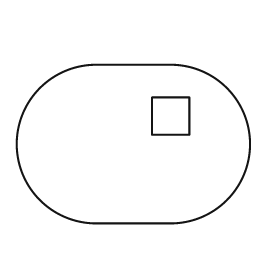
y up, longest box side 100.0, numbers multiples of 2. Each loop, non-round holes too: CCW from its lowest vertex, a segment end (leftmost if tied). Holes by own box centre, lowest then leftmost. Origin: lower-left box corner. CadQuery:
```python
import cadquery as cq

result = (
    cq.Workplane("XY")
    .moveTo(34.0, 0.0)
    .lineTo(66.0, 0.0)
    .threePointArc((100.0, 34.0), (66.0, 68.0))
    .lineTo(34.0, 68.0)
    .threePointArc((0.0, 34.0), (34.0, 0.0))
    .close()
    .moveTo(58.0, 38.0)
    .lineTo(74.0, 38.0)
    .lineTo(74.0, 54.0)
    .lineTo(58.0, 54.0)
    .close()
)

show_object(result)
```